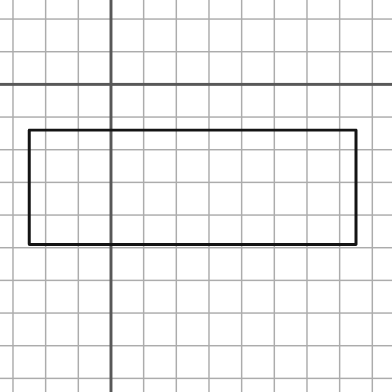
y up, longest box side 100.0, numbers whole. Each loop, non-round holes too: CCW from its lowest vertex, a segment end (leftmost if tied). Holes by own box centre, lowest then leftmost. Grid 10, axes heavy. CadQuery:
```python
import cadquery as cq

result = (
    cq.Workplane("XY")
    .moveTo(-25.0, -49.0)
    .lineTo(75.0, -49.0)
    .lineTo(75.0, -14.0)
    .lineTo(-25.0, -14.0)
    .close()
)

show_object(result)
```